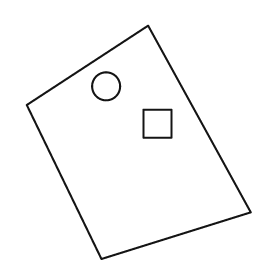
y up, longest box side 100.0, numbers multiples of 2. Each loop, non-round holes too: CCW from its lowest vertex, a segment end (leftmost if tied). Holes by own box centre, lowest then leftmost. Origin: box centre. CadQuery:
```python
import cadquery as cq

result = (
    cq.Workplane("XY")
    .moveTo(-16.0, -50.0)
    .lineTo(48.0, -30.0)
    .lineTo(4.0, 50.0)
    .lineTo(-48.0, 16.0)
    .close()
    .moveTo(2.0, 2.0)
    .lineTo(14.0, 2.0)
    .lineTo(14.0, 14.0)
    .lineTo(2.0, 14.0)
    .close()
    .moveTo(-14.0, 24.0)
    .circle(6.0)
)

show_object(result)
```